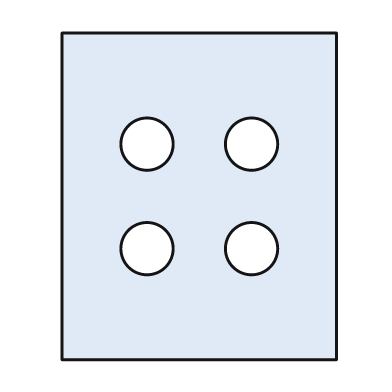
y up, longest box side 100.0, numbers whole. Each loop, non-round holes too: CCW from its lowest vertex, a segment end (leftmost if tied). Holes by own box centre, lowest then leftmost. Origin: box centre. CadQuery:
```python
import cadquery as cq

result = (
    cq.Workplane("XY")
    .moveTo(-42.0, -50.0)
    .lineTo(42.0, -50.0)
    .lineTo(42.0, 50.0)
    .lineTo(-42.0, 50.0)
    .close()
    .moveTo(-16.0, -16.0)
    .circle(8.0)
    .moveTo(16.0, -16.0)
    .circle(8.0)
    .moveTo(-16.0, 16.0)
    .circle(8.0)
    .moveTo(16.0, 16.0)
    .circle(8.0)
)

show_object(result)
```